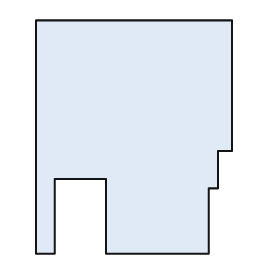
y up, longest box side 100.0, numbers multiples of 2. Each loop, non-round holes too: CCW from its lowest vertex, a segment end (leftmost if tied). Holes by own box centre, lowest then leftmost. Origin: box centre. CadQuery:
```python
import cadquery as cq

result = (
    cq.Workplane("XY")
    .moveTo(-42.0, -50.0)
    .lineTo(-34.0, -50.0)
    .lineTo(-34.0, -18.0)
    .lineTo(-12.0, -18.0)
    .lineTo(-12.0, -50.0)
    .lineTo(32.0, -50.0)
    .lineTo(32.0, -22.0)
    .lineTo(36.0, -22.0)
    .lineTo(36.0, -6.0)
    .lineTo(42.0, -6.0)
    .lineTo(42.0, 50.0)
    .lineTo(-42.0, 50.0)
    .close()
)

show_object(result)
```